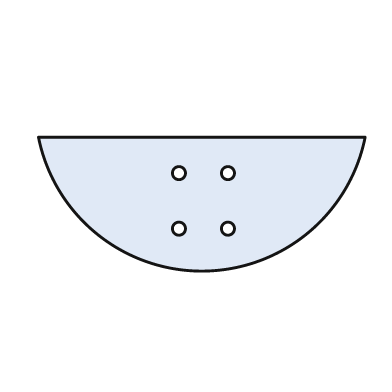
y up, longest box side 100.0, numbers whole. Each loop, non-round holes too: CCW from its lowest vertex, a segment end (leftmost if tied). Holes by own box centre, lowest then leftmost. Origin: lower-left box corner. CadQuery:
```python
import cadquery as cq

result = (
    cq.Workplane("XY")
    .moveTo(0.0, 41.0)
    .threePointArc((50.0, 0.0), (100.0, 41.0))
    .close()
    .moveTo(43.0, 13.0)
    .circle(2.0)
    .moveTo(58.0, 13.0)
    .circle(2.0)
    .moveTo(43.0, 30.0)
    .circle(2.0)
    .moveTo(58.0, 30.0)
    .circle(2.0)
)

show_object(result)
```